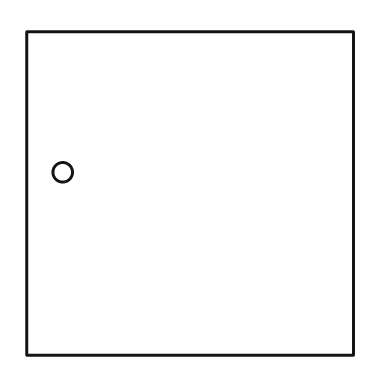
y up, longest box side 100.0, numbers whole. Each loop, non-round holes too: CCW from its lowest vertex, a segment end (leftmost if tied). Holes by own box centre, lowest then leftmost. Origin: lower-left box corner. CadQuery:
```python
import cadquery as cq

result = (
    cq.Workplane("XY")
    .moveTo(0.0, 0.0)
    .lineTo(100.0, 0.0)
    .lineTo(100.0, 99.0)
    .lineTo(0.0, 99.0)
    .close()
    .moveTo(11.0, 56.0)
    .circle(3.0)
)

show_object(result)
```